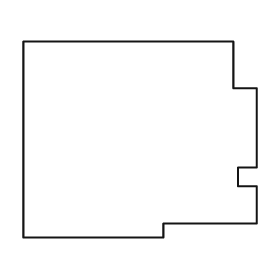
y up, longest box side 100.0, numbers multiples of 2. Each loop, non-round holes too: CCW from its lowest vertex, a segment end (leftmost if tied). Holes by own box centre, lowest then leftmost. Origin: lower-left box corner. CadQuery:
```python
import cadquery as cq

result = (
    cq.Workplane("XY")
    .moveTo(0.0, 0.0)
    .lineTo(60.0, 0.0)
    .lineTo(60.0, 6.0)
    .lineTo(100.0, 6.0)
    .lineTo(100.0, 22.0)
    .lineTo(92.0, 22.0)
    .lineTo(92.0, 30.0)
    .lineTo(100.0, 30.0)
    .lineTo(100.0, 64.0)
    .lineTo(90.0, 64.0)
    .lineTo(90.0, 84.0)
    .lineTo(0.0, 84.0)
    .close()
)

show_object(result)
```